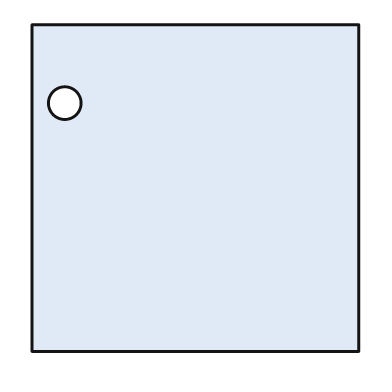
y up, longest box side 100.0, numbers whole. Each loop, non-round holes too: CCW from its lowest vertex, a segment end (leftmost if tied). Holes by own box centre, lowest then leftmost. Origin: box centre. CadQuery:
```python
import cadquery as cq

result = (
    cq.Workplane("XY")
    .moveTo(-50.0, -50.0)
    .lineTo(50.0, -50.0)
    .lineTo(50.0, 50.0)
    .lineTo(-50.0, 50.0)
    .close()
    .moveTo(-40.0, 26.0)
    .circle(5.0)
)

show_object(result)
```